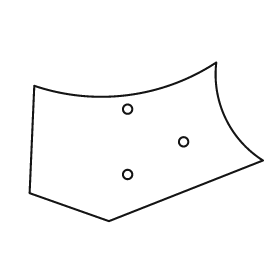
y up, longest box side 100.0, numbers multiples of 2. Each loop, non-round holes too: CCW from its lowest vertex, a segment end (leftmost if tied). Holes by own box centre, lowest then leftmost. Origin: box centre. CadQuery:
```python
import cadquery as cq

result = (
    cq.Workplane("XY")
    .moveTo(-16.0, -34.0)
    .lineTo(50.0, -8.0)
    .threePointArc((34.0, 10.0), (30.0, 34.0))
    .threePointArc((-8.0, 20.0), (-48.0, 24.0))
    .lineTo(-50.0, -22.0)
    .close()
    .moveTo(-8.0, -14.0)
    .circle(2.0)
    .moveTo(16.0, 0.0)
    .circle(2.0)
    .moveTo(-8.0, 14.0)
    .circle(2.0)
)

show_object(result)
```